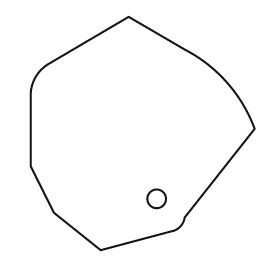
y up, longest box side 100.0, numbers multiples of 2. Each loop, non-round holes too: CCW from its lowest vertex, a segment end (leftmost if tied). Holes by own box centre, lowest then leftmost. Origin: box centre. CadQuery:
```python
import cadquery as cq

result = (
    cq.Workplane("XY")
    .moveTo(-18.0, -50.0)
    .lineTo(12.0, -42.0)
    .threePointArc((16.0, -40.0), (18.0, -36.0))
    .lineTo(48.0, 2.0)
    .threePointArc((36.0, 22.0), (18.0, 36.0))
    .lineTo(-6.0, 50.0)
    .lineTo(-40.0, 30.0)
    .threePointArc((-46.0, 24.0), (-48.0, 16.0))
    .lineTo(-48.0, -14.0)
    .lineTo(-38.0, -34.0)
    .close()
    .moveTo(6.0, -28.0)
    .circle(4.0)
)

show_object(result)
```